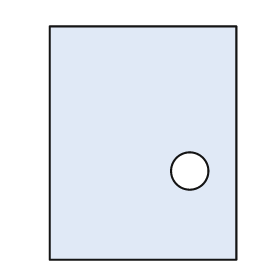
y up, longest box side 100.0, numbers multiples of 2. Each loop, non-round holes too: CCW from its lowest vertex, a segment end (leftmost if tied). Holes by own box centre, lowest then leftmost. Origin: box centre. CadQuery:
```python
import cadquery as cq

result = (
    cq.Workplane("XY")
    .moveTo(-40.0, -50.0)
    .lineTo(40.0, -50.0)
    .lineTo(40.0, 50.0)
    .lineTo(-40.0, 50.0)
    .close()
    .moveTo(20.0, -12.0)
    .circle(8.0)
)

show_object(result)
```